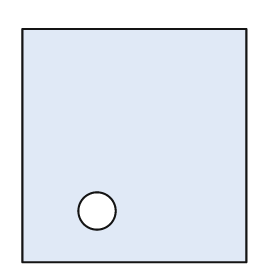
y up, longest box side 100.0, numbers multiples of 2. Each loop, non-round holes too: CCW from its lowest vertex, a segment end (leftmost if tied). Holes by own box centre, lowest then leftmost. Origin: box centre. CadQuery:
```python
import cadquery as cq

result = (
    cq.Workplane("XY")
    .moveTo(-48.0, -50.0)
    .lineTo(48.0, -50.0)
    .lineTo(48.0, 50.0)
    .lineTo(-48.0, 50.0)
    .close()
    .moveTo(-16.0, -28.0)
    .circle(8.0)
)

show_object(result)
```